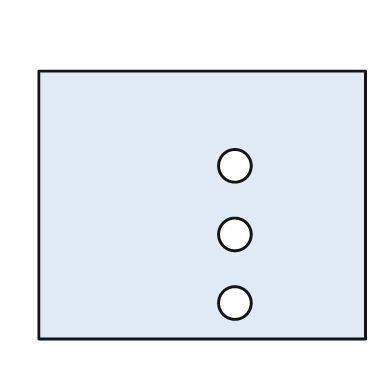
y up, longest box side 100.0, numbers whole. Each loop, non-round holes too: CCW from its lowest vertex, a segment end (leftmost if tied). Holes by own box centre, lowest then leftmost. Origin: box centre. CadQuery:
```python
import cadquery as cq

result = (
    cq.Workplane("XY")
    .moveTo(-50.0, -41.0)
    .lineTo(50.0, -41.0)
    .lineTo(50.0, 41.0)
    .lineTo(-50.0, 41.0)
    .close()
    .moveTo(10.0, -30.0)
    .circle(5.0)
    .moveTo(10.0, -9.0)
    .circle(5.0)
    .moveTo(10.0, 12.0)
    .circle(5.0)
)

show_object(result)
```